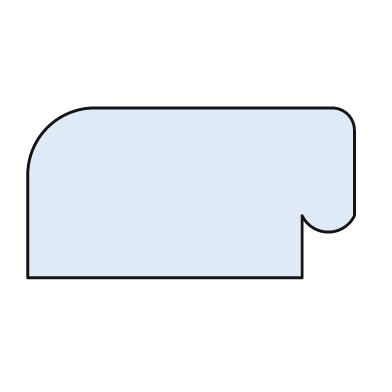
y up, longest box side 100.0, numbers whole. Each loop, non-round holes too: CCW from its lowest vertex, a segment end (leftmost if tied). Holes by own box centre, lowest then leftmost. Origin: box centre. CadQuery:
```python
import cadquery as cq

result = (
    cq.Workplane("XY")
    .moveTo(-50.0, -26.0)
    .lineTo(34.0, -26.0)
    .lineTo(34.0, -7.0)
    .threePointArc((42.0, -12.0), (50.0, -7.0))
    .lineTo(50.0, 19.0)
    .threePointArc((48.0, 24.0), (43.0, 26.0))
    .lineTo(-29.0, 26.0)
    .threePointArc((-44.0, 20.0), (-50.0, 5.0))
    .close()
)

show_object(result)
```